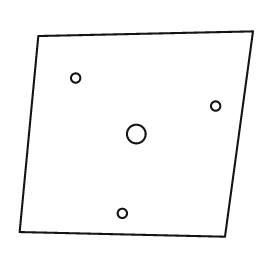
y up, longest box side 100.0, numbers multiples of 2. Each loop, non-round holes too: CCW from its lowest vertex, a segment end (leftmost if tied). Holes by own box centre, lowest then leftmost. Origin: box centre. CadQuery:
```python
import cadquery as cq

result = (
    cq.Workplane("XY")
    .moveTo(38.0, -44.0)
    .lineTo(50.0, 44.0)
    .lineTo(-42.0, 42.0)
    .lineTo(-50.0, -42.0)
    .close()
    .moveTo(-6.0, -34.0)
    .circle(2.0)
    .moveTo(0.0, 0.0)
    .circle(4.0)
    .moveTo(34.0, 12.0)
    .circle(2.0)
    .moveTo(-26.0, 24.0)
    .circle(2.0)
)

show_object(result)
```